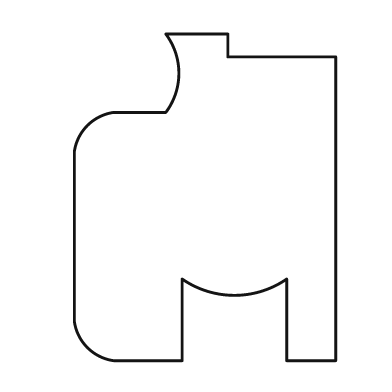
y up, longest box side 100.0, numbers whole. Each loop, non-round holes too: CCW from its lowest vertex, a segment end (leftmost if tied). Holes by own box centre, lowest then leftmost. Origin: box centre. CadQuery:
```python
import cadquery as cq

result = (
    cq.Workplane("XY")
    .moveTo(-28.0, -50.0)
    .lineTo(-7.0, -50.0)
    .lineTo(-7.0, -25.0)
    .threePointArc((9.0, -30.0), (25.0, -25.0))
    .lineTo(25.0, -50.0)
    .lineTo(40.0, -50.0)
    .lineTo(40.0, 43.0)
    .lineTo(7.0, 43.0)
    .lineTo(7.0, 50.0)
    .lineTo(-12.0, 50.0)
    .threePointArc((-8.0, 38.0), (-12.0, 26.0))
    .lineTo(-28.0, 26.0)
    .threePointArc((-36.0, 22.0), (-40.0, 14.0))
    .lineTo(-40.0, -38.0)
    .threePointArc((-36.0, -46.0), (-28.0, -50.0))
    .close()
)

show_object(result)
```